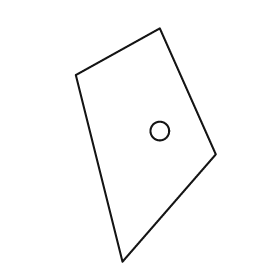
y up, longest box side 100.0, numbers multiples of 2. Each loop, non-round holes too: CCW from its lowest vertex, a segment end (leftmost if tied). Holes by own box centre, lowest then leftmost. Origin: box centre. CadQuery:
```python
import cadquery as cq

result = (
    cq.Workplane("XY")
    .moveTo(-10.0, -50.0)
    .lineTo(30.0, -4.0)
    .lineTo(6.0, 50.0)
    .lineTo(-30.0, 30.0)
    .close()
    .moveTo(6.0, 6.0)
    .circle(4.0)
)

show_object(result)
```